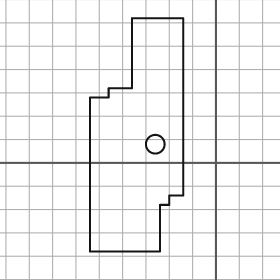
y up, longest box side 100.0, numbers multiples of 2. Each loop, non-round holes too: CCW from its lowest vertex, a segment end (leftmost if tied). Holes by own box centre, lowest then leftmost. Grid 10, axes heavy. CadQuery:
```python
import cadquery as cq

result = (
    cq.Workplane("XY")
    .moveTo(-54.0, -38.0)
    .lineTo(-24.0, -38.0)
    .lineTo(-24.0, -18.0)
    .lineTo(-20.0, -18.0)
    .lineTo(-20.0, -14.0)
    .lineTo(-14.0, -14.0)
    .lineTo(-14.0, 62.0)
    .lineTo(-36.0, 62.0)
    .lineTo(-36.0, 32.0)
    .lineTo(-46.0, 32.0)
    .lineTo(-46.0, 28.0)
    .lineTo(-54.0, 28.0)
    .close()
    .moveTo(-26.0, 8.0)
    .circle(4.0)
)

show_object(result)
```